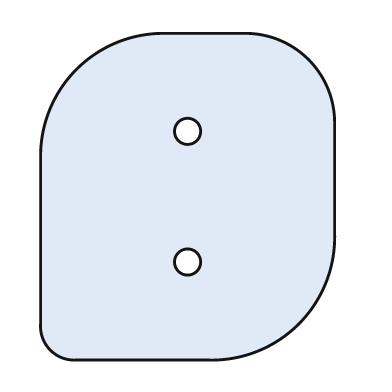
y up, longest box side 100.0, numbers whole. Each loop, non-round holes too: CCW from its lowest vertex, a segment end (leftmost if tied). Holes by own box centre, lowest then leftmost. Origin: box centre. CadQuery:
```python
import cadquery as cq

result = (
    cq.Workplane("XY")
    .moveTo(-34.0, -50.0)
    .lineTo(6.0, -50.0)
    .threePointArc((34.0, -39.0), (45.0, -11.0))
    .lineTo(45.0, 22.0)
    .threePointArc((37.0, 42.0), (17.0, 50.0))
    .lineTo(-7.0, 50.0)
    .threePointArc((-34.0, 39.0), (-45.0, 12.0))
    .lineTo(-45.0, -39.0)
    .threePointArc((-42.0, -47.0), (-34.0, -50.0))
    .close()
    .moveTo(0.0, -20.0)
    .circle(4.0)
    .moveTo(0.0, 20.0)
    .circle(4.0)
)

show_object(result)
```